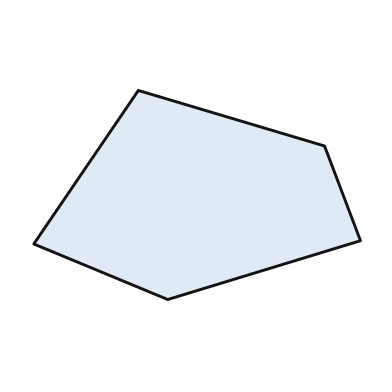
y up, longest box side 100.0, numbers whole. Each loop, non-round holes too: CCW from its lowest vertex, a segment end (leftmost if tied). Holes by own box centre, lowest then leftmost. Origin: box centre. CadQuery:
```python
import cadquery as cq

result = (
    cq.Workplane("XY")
    .moveTo(-9.0, -32.0)
    .lineTo(50.0, -14.0)
    .lineTo(39.0, 15.0)
    .lineTo(-18.0, 32.0)
    .lineTo(-50.0, -15.0)
    .close()
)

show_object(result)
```